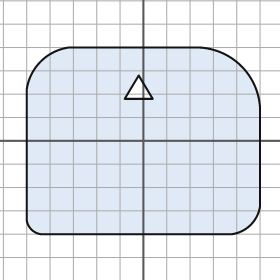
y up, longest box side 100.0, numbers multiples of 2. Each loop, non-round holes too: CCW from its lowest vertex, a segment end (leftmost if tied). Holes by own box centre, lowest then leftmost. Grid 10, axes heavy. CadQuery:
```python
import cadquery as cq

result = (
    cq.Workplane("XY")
    .moveTo(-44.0, -40.0)
    .lineTo(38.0, -40.0)
    .threePointArc((46.0, -36.0), (50.0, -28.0))
    .lineTo(50.0, 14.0)
    .threePointArc((42.0, 32.0), (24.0, 40.0))
    .lineTo(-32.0, 40.0)
    .threePointArc((-44.0, 34.0), (-50.0, 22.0))
    .lineTo(-50.0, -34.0)
    .threePointArc((-48.0, -38.0), (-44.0, -40.0))
    .close()
    .moveTo(-8.0, 18.0)
    .lineTo(4.0, 18.0)
    .lineTo(-2.0, 28.0)
    .close()
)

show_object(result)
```